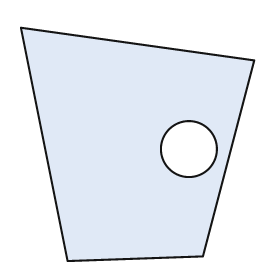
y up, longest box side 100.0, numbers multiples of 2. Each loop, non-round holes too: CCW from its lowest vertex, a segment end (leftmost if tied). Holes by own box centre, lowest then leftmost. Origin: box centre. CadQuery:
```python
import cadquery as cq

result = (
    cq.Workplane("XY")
    .moveTo(-30.0, -50.0)
    .lineTo(28.0, -48.0)
    .lineTo(50.0, 36.0)
    .lineTo(-50.0, 50.0)
    .close()
    .moveTo(22.0, -2.0)
    .circle(12.0)
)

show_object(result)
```